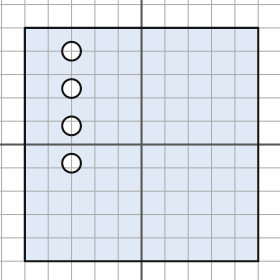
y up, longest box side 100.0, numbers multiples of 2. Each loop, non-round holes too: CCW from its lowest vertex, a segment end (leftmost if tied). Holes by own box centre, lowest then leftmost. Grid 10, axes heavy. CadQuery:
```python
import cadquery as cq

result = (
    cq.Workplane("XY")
    .moveTo(-50.0, -50.0)
    .lineTo(50.0, -50.0)
    .lineTo(50.0, 50.0)
    .lineTo(-50.0, 50.0)
    .close()
    .moveTo(-30.0, -8.0)
    .circle(4.0)
    .moveTo(-30.0, 8.0)
    .circle(4.0)
    .moveTo(-30.0, 24.0)
    .circle(4.0)
    .moveTo(-30.0, 40.0)
    .circle(4.0)
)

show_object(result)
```